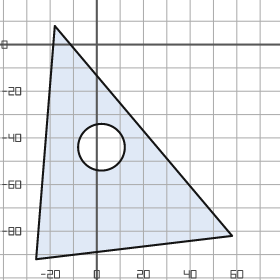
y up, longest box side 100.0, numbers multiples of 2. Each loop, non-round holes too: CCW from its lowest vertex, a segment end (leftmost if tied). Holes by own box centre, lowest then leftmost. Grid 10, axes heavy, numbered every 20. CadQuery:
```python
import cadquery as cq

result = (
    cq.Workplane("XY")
    .moveTo(-26.0, -92.0)
    .lineTo(58.0, -82.0)
    .lineTo(-18.0, 8.0)
    .close()
    .moveTo(2.0, -44.0)
    .circle(10.0)
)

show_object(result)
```